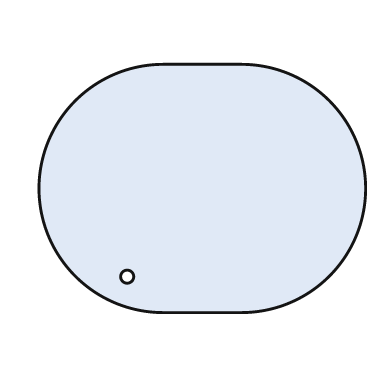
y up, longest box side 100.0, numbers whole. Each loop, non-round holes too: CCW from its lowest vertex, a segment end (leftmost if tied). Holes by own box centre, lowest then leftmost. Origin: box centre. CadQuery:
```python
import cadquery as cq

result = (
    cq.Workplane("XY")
    .moveTo(-12.0, -38.0)
    .lineTo(12.0, -38.0)
    .threePointArc((50.0, 0.0), (12.0, 38.0))
    .lineTo(-12.0, 38.0)
    .threePointArc((-50.0, 0.0), (-12.0, -38.0))
    .close()
    .moveTo(-23.0, -27.0)
    .circle(2.0)
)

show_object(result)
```